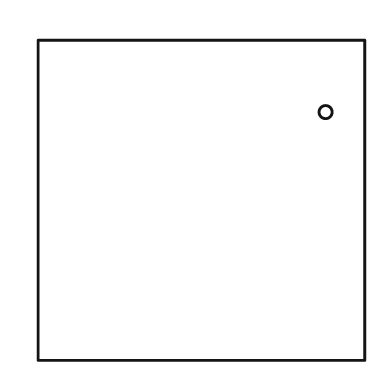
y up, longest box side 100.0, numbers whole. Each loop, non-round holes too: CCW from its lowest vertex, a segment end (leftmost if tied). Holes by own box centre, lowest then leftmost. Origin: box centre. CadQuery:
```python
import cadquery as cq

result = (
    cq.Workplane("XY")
    .moveTo(-50.0, -49.0)
    .lineTo(50.0, -49.0)
    .lineTo(50.0, 49.0)
    .lineTo(-50.0, 49.0)
    .close()
    .moveTo(38.0, 27.0)
    .circle(2.0)
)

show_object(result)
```